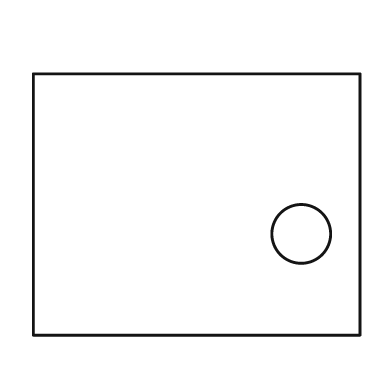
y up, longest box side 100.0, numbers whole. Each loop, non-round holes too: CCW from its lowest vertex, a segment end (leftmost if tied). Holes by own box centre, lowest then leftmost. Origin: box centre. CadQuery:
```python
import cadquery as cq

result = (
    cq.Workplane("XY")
    .moveTo(-50.0, -40.0)
    .lineTo(50.0, -40.0)
    .lineTo(50.0, 40.0)
    .lineTo(-50.0, 40.0)
    .close()
    .moveTo(32.0, -9.0)
    .circle(9.0)
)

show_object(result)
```